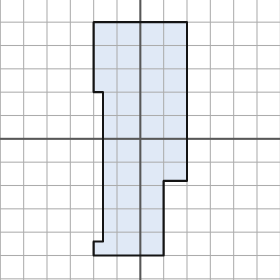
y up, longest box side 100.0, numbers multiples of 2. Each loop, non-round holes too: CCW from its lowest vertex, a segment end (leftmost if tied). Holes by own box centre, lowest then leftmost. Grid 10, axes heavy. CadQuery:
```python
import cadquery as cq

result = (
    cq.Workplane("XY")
    .moveTo(-20.0, -50.0)
    .lineTo(10.0, -50.0)
    .lineTo(10.0, -18.0)
    .lineTo(20.0, -18.0)
    .lineTo(20.0, 50.0)
    .lineTo(-20.0, 50.0)
    .lineTo(-20.0, 20.0)
    .lineTo(-16.0, 20.0)
    .lineTo(-16.0, -44.0)
    .lineTo(-20.0, -44.0)
    .close()
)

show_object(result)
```